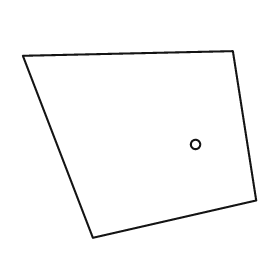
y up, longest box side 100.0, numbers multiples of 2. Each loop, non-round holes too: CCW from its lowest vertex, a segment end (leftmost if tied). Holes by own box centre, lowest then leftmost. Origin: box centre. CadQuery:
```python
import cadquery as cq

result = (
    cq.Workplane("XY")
    .moveTo(-20.0, -40.0)
    .lineTo(50.0, -24.0)
    .lineTo(40.0, 40.0)
    .lineTo(-50.0, 38.0)
    .close()
    .moveTo(24.0, 0.0)
    .circle(2.0)
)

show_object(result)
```